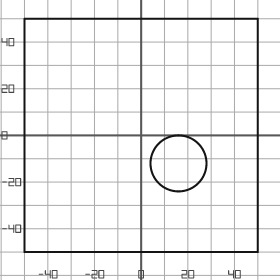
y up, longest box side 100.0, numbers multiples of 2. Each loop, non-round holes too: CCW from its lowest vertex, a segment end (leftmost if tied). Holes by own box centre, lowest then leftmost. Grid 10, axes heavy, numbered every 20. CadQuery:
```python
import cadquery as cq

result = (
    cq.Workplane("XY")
    .moveTo(-50.0, -50.0)
    .lineTo(50.0, -50.0)
    .lineTo(50.0, 50.0)
    .lineTo(-50.0, 50.0)
    .close()
    .moveTo(16.0, -12.0)
    .circle(12.0)
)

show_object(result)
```